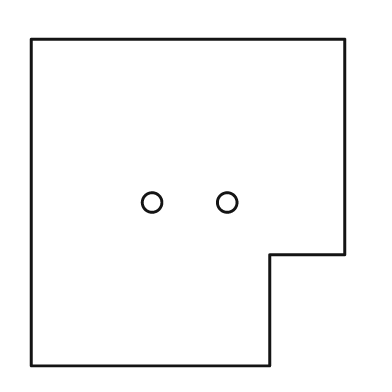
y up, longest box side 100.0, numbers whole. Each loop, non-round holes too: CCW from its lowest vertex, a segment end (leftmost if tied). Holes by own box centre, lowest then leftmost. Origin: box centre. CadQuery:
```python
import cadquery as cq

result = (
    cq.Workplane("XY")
    .moveTo(-48.0, -50.0)
    .lineTo(25.0, -50.0)
    .lineTo(25.0, -16.0)
    .lineTo(48.0, -16.0)
    .lineTo(48.0, 50.0)
    .lineTo(-48.0, 50.0)
    .close()
    .moveTo(-11.0, 0.0)
    .circle(3.0)
    .moveTo(12.0, 0.0)
    .circle(3.0)
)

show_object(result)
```